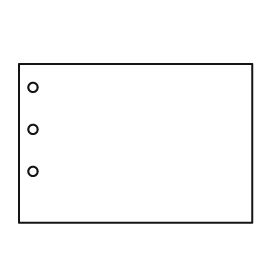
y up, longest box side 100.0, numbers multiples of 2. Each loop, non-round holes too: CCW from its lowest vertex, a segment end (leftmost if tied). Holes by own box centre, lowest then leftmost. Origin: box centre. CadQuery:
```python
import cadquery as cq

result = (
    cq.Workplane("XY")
    .moveTo(-50.0, -34.0)
    .lineTo(50.0, -34.0)
    .lineTo(50.0, 34.0)
    .lineTo(-50.0, 34.0)
    .close()
    .moveTo(-44.0, -12.0)
    .circle(2.0)
    .moveTo(-44.0, 6.0)
    .circle(2.0)
    .moveTo(-44.0, 24.0)
    .circle(2.0)
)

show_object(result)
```